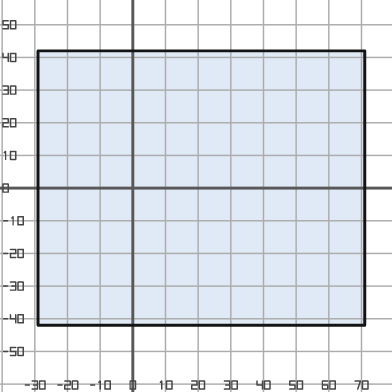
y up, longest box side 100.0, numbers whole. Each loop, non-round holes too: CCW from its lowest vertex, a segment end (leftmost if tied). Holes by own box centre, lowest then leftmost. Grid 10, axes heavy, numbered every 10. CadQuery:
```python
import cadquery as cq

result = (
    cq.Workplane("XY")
    .moveTo(-29.0, -42.0)
    .lineTo(71.0, -42.0)
    .lineTo(71.0, 42.0)
    .lineTo(-29.0, 42.0)
    .close()
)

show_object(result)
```